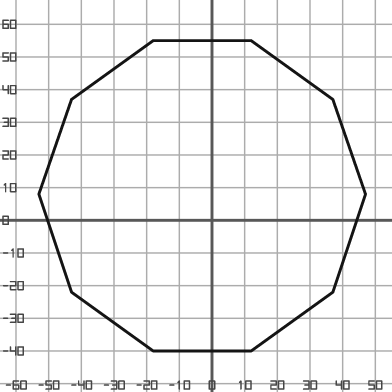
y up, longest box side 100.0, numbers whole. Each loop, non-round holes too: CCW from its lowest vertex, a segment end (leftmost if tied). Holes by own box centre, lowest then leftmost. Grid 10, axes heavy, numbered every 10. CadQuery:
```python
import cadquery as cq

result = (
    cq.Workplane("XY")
    .moveTo(-18.0, -40.0)
    .lineTo(12.0, -40.0)
    .lineTo(37.0, -22.0)
    .lineTo(47.0, 8.0)
    .lineTo(37.0, 37.0)
    .lineTo(12.0, 55.0)
    .lineTo(-18.0, 55.0)
    .lineTo(-43.0, 37.0)
    .lineTo(-53.0, 8.0)
    .lineTo(-43.0, -22.0)
    .close()
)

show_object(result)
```